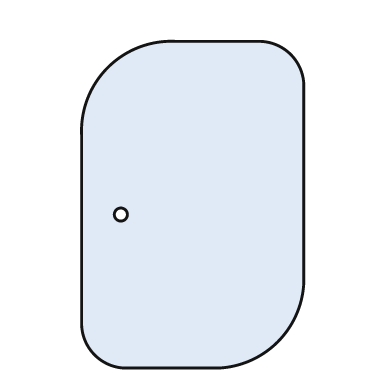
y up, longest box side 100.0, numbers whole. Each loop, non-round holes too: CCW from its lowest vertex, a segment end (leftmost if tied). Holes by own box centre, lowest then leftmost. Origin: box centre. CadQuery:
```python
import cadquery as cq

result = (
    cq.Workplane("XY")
    .moveTo(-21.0, -50.0)
    .lineTo(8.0, -50.0)
    .threePointArc((26.0, -42.0), (34.0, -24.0))
    .lineTo(34.0, 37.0)
    .threePointArc((30.0, 46.0), (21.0, 50.0))
    .lineTo(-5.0, 50.0)
    .threePointArc((-26.0, 42.0), (-34.0, 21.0))
    .lineTo(-34.0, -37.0)
    .threePointArc((-30.0, -46.0), (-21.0, -50.0))
    .close()
    .moveTo(-22.0, -3.0)
    .circle(2.0)
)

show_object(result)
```